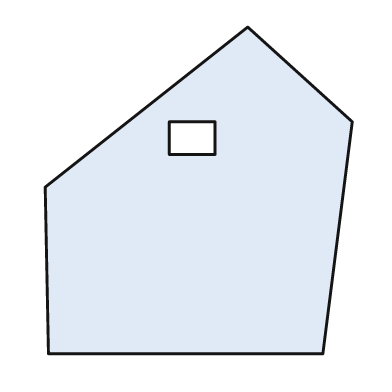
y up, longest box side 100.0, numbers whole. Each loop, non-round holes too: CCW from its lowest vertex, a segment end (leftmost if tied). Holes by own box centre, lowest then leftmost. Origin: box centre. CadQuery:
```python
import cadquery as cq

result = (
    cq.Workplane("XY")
    .moveTo(-46.0, -50.0)
    .lineTo(38.0, -50.0)
    .lineTo(47.0, 21.0)
    .lineTo(15.0, 50.0)
    .lineTo(-47.0, 1.0)
    .close()
    .moveTo(-9.0, 11.0)
    .lineTo(5.0, 11.0)
    .lineTo(5.0, 21.0)
    .lineTo(-9.0, 21.0)
    .close()
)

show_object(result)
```